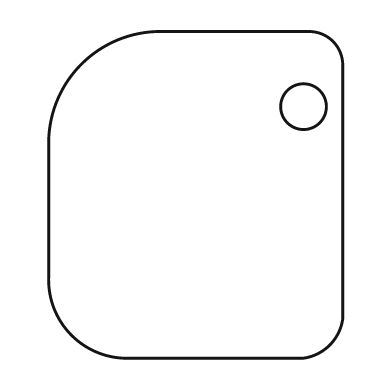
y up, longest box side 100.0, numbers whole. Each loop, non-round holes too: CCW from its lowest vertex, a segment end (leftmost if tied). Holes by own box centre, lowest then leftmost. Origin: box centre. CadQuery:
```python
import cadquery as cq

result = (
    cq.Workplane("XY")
    .moveTo(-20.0, -50.0)
    .lineTo(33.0, -50.0)
    .threePointArc((41.0, -46.0), (45.0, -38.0))
    .lineTo(45.0, 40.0)
    .threePointArc((42.0, 47.0), (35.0, 50.0))
    .lineTo(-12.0, 50.0)
    .threePointArc((-35.0, 40.0), (-45.0, 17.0))
    .lineTo(-45.0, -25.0)
    .threePointArc((-38.0, -43.0), (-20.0, -50.0))
    .close()
    .moveTo(33.0, 27.0)
    .circle(7.0)
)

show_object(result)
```